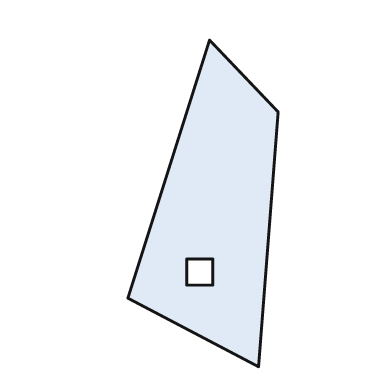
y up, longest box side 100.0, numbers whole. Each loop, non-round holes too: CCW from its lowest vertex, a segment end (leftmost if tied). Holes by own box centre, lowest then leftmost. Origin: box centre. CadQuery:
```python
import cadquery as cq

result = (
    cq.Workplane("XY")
    .moveTo(17.0, -50.0)
    .lineTo(23.0, 28.0)
    .lineTo(2.0, 50.0)
    .lineTo(-23.0, -29.0)
    .close()
    .moveTo(-5.0, -25.0)
    .lineTo(3.0, -25.0)
    .lineTo(3.0, -17.0)
    .lineTo(-5.0, -17.0)
    .close()
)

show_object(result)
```